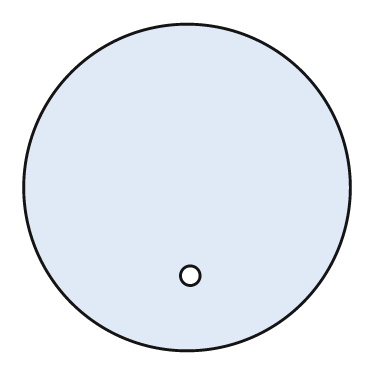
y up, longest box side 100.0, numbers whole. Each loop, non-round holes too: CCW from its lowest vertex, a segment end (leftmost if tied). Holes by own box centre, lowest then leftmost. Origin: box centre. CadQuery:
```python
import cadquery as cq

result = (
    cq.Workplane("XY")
    .moveTo(0.0, 0.0)
    .circle(50.0)
    .moveTo(1.0, -27.0)
    .circle(3.0)
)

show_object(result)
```